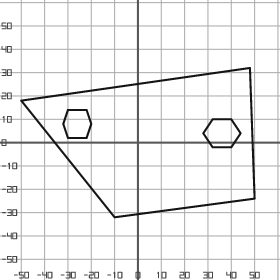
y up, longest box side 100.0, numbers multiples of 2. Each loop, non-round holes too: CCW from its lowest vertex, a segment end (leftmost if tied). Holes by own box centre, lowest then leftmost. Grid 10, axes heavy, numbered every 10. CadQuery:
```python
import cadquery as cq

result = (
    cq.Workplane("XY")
    .moveTo(-10.0, -32.0)
    .lineTo(50.0, -24.0)
    .lineTo(48.0, 32.0)
    .lineTo(-50.0, 18.0)
    .close()
    .moveTo(32.0, -2.0)
    .lineTo(40.0, -2.0)
    .lineTo(44.0, 4.0)
    .lineTo(40.0, 10.0)
    .lineTo(32.0, 10.0)
    .lineTo(28.0, 4.0)
    .close()
    .moveTo(-30.0, 2.0)
    .lineTo(-22.0, 2.0)
    .lineTo(-20.0, 8.0)
    .lineTo(-22.0, 14.0)
    .lineTo(-30.0, 14.0)
    .lineTo(-32.0, 8.0)
    .close()
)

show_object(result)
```